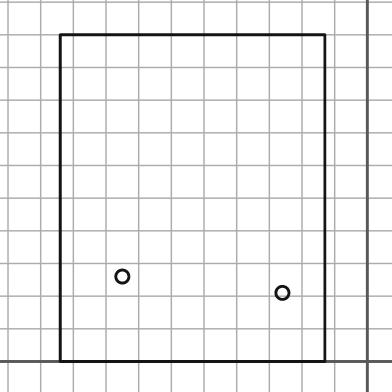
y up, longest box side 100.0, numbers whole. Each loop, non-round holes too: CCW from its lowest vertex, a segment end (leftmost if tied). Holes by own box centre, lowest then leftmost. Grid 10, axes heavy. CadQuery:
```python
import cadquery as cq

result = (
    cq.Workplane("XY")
    .moveTo(-94.0, 0.0)
    .lineTo(-13.0, 0.0)
    .lineTo(-13.0, 100.0)
    .lineTo(-94.0, 100.0)
    .close()
    .moveTo(-26.0, 21.0)
    .circle(2.0)
    .moveTo(-75.0, 26.0)
    .circle(2.0)
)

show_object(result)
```